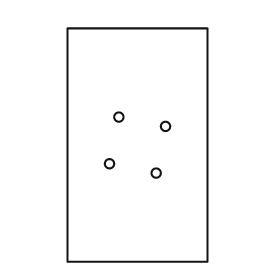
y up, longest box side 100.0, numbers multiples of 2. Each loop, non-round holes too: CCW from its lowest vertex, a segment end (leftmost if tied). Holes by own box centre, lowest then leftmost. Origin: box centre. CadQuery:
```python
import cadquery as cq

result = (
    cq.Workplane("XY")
    .moveTo(-30.0, -50.0)
    .lineTo(30.0, -50.0)
    .lineTo(30.0, 50.0)
    .lineTo(-30.0, 50.0)
    .close()
    .moveTo(8.0, -12.0)
    .circle(2.0)
    .moveTo(-12.0, -8.0)
    .circle(2.0)
    .moveTo(12.0, 8.0)
    .circle(2.0)
    .moveTo(-8.0, 12.0)
    .circle(2.0)
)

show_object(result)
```